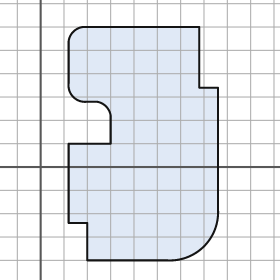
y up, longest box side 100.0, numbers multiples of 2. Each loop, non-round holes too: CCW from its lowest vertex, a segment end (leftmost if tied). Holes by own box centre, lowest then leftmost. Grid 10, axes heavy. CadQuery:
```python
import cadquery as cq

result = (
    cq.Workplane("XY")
    .moveTo(20.0, -40.0)
    .lineTo(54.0, -40.0)
    .threePointArc((70.0, -34.0), (76.0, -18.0))
    .lineTo(76.0, 34.0)
    .lineTo(68.0, 34.0)
    .lineTo(68.0, 60.0)
    .lineTo(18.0, 60.0)
    .threePointArc((14.0, 58.0), (12.0, 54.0))
    .lineTo(12.0, 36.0)
    .threePointArc((14.0, 30.0), (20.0, 28.0))
    .lineTo(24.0, 28.0)
    .threePointArc((28.0, 26.0), (30.0, 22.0))
    .lineTo(30.0, 10.0)
    .lineTo(12.0, 10.0)
    .lineTo(12.0, -24.0)
    .lineTo(20.0, -24.0)
    .close()
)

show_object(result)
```